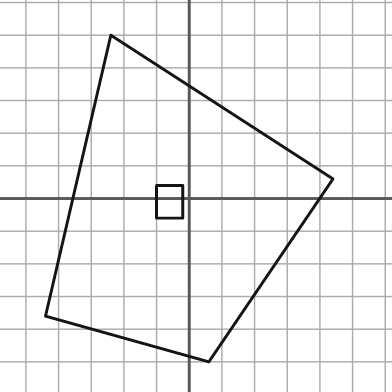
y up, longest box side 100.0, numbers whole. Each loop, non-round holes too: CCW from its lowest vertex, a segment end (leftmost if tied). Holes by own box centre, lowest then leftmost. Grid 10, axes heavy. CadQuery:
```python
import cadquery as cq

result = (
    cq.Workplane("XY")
    .moveTo(6.0, -50.0)
    .lineTo(44.0, 6.0)
    .lineTo(-24.0, 50.0)
    .lineTo(-44.0, -36.0)
    .close()
    .moveTo(-10.0, -6.0)
    .lineTo(-2.0, -6.0)
    .lineTo(-2.0, 4.0)
    .lineTo(-10.0, 4.0)
    .close()
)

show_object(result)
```